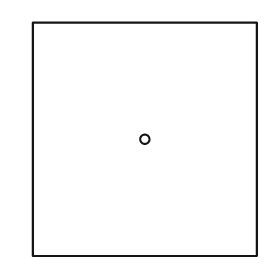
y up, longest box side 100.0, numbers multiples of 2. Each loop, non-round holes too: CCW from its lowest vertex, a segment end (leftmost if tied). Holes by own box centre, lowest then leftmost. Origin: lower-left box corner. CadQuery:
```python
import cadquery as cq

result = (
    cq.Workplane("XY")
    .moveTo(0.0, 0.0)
    .lineTo(96.0, 0.0)
    .lineTo(96.0, 100.0)
    .lineTo(0.0, 100.0)
    .close()
    .moveTo(48.0, 50.0)
    .circle(2.0)
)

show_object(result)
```